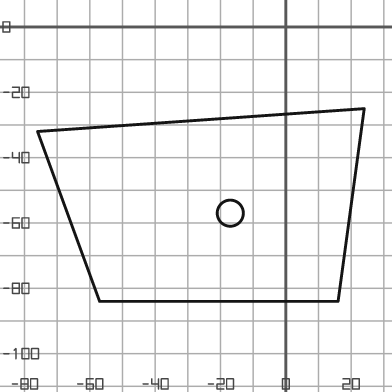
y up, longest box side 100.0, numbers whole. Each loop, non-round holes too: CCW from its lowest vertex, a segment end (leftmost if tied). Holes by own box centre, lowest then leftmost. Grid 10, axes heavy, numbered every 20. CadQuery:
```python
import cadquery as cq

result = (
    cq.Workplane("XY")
    .moveTo(-57.0, -84.0)
    .lineTo(16.0, -84.0)
    .lineTo(24.0, -25.0)
    .lineTo(-76.0, -32.0)
    .close()
    .moveTo(-17.0, -57.0)
    .circle(4.0)
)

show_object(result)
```